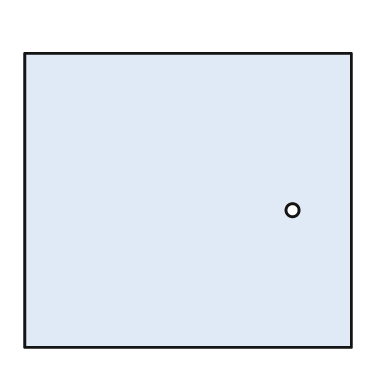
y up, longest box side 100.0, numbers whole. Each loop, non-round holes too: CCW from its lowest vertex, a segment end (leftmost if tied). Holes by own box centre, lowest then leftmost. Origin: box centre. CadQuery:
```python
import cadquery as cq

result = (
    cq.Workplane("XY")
    .moveTo(-50.0, -45.0)
    .lineTo(50.0, -45.0)
    .lineTo(50.0, 45.0)
    .lineTo(-50.0, 45.0)
    .close()
    .moveTo(32.0, -3.0)
    .circle(2.0)
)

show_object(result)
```